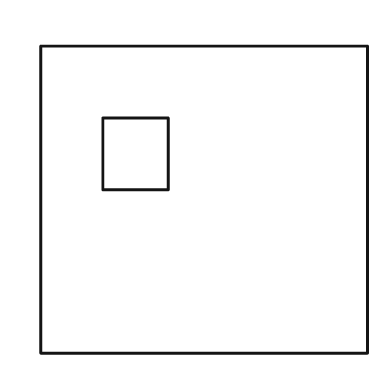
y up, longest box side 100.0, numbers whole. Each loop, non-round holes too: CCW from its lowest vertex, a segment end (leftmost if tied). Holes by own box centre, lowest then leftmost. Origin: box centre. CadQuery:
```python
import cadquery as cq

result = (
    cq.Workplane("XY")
    .moveTo(-50.0, -47.0)
    .lineTo(50.0, -47.0)
    .lineTo(50.0, 47.0)
    .lineTo(-50.0, 47.0)
    .close()
    .moveTo(-31.0, 3.0)
    .lineTo(-11.0, 3.0)
    .lineTo(-11.0, 25.0)
    .lineTo(-31.0, 25.0)
    .close()
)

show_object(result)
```